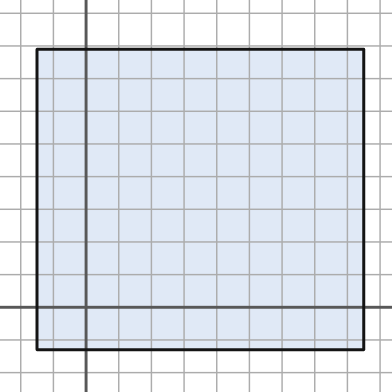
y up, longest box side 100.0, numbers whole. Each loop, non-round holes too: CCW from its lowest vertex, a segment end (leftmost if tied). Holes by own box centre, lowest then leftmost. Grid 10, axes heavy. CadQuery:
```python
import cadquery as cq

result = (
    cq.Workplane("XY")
    .moveTo(-15.0, -13.0)
    .lineTo(85.0, -13.0)
    .lineTo(85.0, 79.0)
    .lineTo(-15.0, 79.0)
    .close()
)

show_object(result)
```